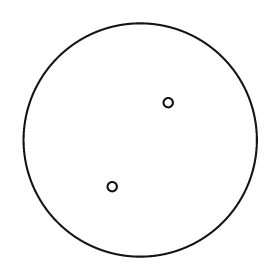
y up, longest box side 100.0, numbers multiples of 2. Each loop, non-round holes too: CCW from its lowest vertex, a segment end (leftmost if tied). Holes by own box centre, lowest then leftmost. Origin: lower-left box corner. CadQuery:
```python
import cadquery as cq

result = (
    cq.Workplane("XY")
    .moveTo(50.0, 50.0)
    .circle(50.0)
    .moveTo(38.0, 30.0)
    .circle(2.0)
    .moveTo(62.0, 66.0)
    .circle(2.0)
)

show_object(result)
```